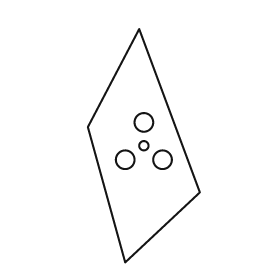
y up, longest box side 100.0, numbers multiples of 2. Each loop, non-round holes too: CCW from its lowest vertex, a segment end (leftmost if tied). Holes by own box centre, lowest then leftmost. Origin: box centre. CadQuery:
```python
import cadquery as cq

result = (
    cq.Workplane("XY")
    .moveTo(-8.0, -50.0)
    .lineTo(24.0, -20.0)
    .lineTo(-2.0, 50.0)
    .lineTo(-24.0, 8.0)
    .close()
    .moveTo(-8.0, -6.0)
    .circle(4.0)
    .moveTo(8.0, -6.0)
    .circle(4.0)
    .moveTo(0.0, 0.0)
    .circle(2.0)
    .moveTo(0.0, 10.0)
    .circle(4.0)
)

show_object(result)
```